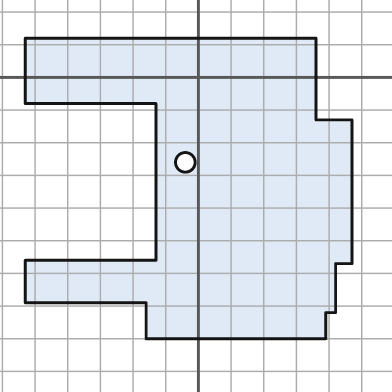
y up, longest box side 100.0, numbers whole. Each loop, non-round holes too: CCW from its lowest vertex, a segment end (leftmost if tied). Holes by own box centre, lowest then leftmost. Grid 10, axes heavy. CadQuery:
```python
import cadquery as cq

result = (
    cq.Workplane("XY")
    .moveTo(-16.0, -80.0)
    .lineTo(39.0, -80.0)
    .lineTo(39.0, -72.0)
    .lineTo(42.0, -72.0)
    .lineTo(42.0, -57.0)
    .lineTo(47.0, -57.0)
    .lineTo(47.0, -13.0)
    .lineTo(36.0, -13.0)
    .lineTo(36.0, 12.0)
    .lineTo(-53.0, 12.0)
    .lineTo(-53.0, -8.0)
    .lineTo(-13.0, -8.0)
    .lineTo(-13.0, -56.0)
    .lineTo(-53.0, -56.0)
    .lineTo(-53.0, -69.0)
    .lineTo(-16.0, -69.0)
    .close()
    .moveTo(-4.0, -26.0)
    .circle(3.0)
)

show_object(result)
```